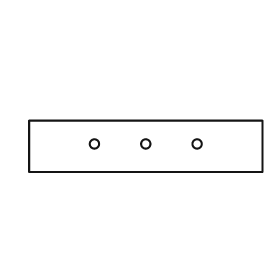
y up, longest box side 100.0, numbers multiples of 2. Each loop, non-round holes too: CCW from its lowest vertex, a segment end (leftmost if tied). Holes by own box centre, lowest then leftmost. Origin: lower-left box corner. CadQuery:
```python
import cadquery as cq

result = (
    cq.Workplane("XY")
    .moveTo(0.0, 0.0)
    .lineTo(100.0, 0.0)
    .lineTo(100.0, 22.0)
    .lineTo(0.0, 22.0)
    .close()
    .moveTo(28.0, 12.0)
    .circle(2.0)
    .moveTo(50.0, 12.0)
    .circle(2.0)
    .moveTo(72.0, 12.0)
    .circle(2.0)
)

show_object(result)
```